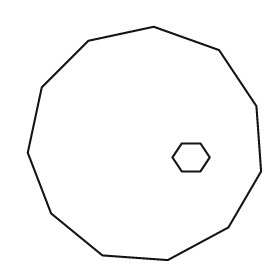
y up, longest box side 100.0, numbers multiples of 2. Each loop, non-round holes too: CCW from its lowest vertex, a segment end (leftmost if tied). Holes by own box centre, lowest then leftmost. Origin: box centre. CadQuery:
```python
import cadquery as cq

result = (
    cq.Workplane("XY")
    .moveTo(10.0, -50.0)
    .lineTo(36.0, -36.0)
    .lineTo(50.0, -12.0)
    .lineTo(48.0, 16.0)
    .lineTo(32.0, 40.0)
    .lineTo(4.0, 50.0)
    .lineTo(-24.0, 44.0)
    .lineTo(-44.0, 24.0)
    .lineTo(-50.0, -4.0)
    .lineTo(-40.0, -30.0)
    .lineTo(-18.0, -48.0)
    .close()
    .moveTo(16.0, -12.0)
    .lineTo(24.0, -12.0)
    .lineTo(28.0, -6.0)
    .lineTo(24.0, 0.0)
    .lineTo(16.0, 0.0)
    .lineTo(12.0, -6.0)
    .close()
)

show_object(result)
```